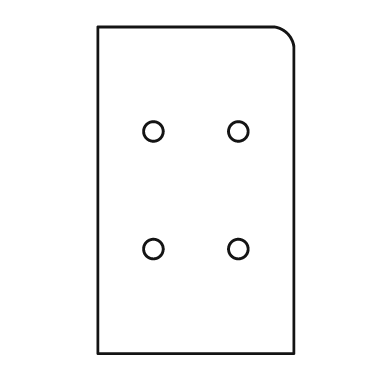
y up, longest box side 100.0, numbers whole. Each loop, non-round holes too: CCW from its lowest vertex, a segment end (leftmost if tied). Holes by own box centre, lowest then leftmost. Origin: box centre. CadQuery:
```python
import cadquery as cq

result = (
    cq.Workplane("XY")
    .moveTo(-30.0, -50.0)
    .lineTo(30.0, -50.0)
    .lineTo(30.0, 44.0)
    .threePointArc((28.0, 48.0), (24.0, 50.0))
    .lineTo(-30.0, 50.0)
    .close()
    .moveTo(-13.0, -18.0)
    .circle(3.0)
    .moveTo(13.0, -18.0)
    .circle(3.0)
    .moveTo(-13.0, 18.0)
    .circle(3.0)
    .moveTo(13.0, 18.0)
    .circle(3.0)
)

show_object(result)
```